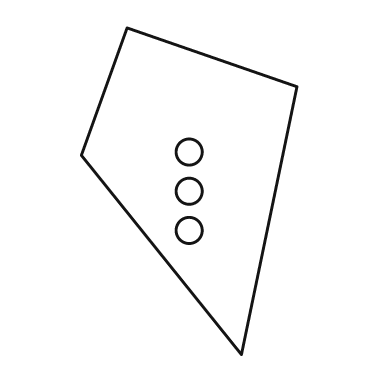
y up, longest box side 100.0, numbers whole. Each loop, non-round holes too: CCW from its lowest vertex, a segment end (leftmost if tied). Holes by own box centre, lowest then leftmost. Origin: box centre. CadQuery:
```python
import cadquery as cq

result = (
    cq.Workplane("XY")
    .moveTo(16.0, -50.0)
    .lineTo(33.0, 32.0)
    .lineTo(-19.0, 50.0)
    .lineTo(-33.0, 11.0)
    .close()
    .moveTo(0.0, -12.0)
    .circle(4.0)
    .moveTo(0.0, 0.0)
    .circle(4.0)
    .moveTo(0.0, 12.0)
    .circle(4.0)
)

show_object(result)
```